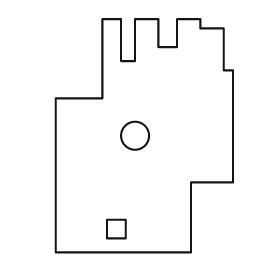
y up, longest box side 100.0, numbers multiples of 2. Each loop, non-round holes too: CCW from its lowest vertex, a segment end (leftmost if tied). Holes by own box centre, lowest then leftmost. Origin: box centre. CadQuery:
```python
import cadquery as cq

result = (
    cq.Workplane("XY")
    .moveTo(-38.0, -50.0)
    .lineTo(20.0, -50.0)
    .lineTo(20.0, -20.0)
    .lineTo(38.0, -20.0)
    .lineTo(38.0, 28.0)
    .lineTo(34.0, 28.0)
    .lineTo(34.0, 46.0)
    .lineTo(24.0, 46.0)
    .lineTo(24.0, 50.0)
    .lineTo(14.0, 50.0)
    .lineTo(14.0, 38.0)
    .lineTo(6.0, 38.0)
    .lineTo(6.0, 50.0)
    .lineTo(-4.0, 50.0)
    .lineTo(-4.0, 32.0)
    .lineTo(-10.0, 32.0)
    .lineTo(-10.0, 50.0)
    .lineTo(-18.0, 50.0)
    .lineTo(-18.0, 16.0)
    .lineTo(-38.0, 16.0)
    .close()
    .moveTo(-16.0, -44.0)
    .lineTo(-8.0, -44.0)
    .lineTo(-8.0, -36.0)
    .lineTo(-16.0, -36.0)
    .close()
    .moveTo(-4.0, 0.0)
    .circle(6.0)
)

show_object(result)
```